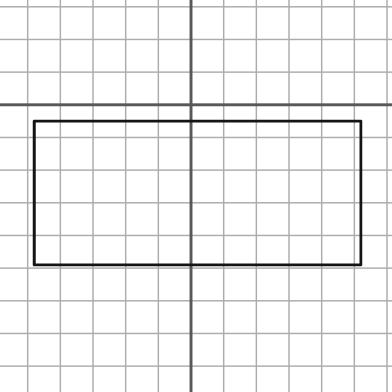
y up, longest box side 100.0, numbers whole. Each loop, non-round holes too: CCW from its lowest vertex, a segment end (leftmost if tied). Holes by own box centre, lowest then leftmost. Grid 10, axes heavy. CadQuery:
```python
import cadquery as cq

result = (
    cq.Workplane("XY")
    .moveTo(-48.0, -49.0)
    .lineTo(52.0, -49.0)
    .lineTo(52.0, -5.0)
    .lineTo(-48.0, -5.0)
    .close()
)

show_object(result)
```